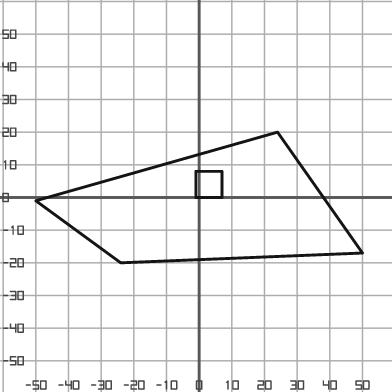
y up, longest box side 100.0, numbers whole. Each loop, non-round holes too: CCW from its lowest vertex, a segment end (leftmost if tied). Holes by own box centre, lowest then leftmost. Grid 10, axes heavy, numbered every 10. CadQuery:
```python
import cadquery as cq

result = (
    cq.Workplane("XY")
    .moveTo(-24.0, -20.0)
    .lineTo(50.0, -17.0)
    .lineTo(24.0, 20.0)
    .lineTo(-50.0, -1.0)
    .close()
    .moveTo(-1.0, 0.0)
    .lineTo(7.0, 0.0)
    .lineTo(7.0, 8.0)
    .lineTo(-1.0, 8.0)
    .close()
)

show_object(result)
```